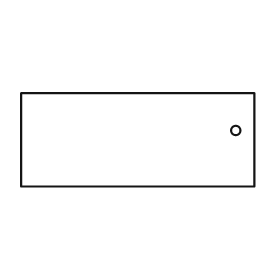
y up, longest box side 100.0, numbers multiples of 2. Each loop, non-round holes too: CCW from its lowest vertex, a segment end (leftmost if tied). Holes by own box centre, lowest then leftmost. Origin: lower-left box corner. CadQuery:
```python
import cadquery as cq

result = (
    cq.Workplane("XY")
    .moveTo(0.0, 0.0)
    .lineTo(100.0, 0.0)
    .lineTo(100.0, 40.0)
    .lineTo(0.0, 40.0)
    .close()
    .moveTo(92.0, 24.0)
    .circle(2.0)
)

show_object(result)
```